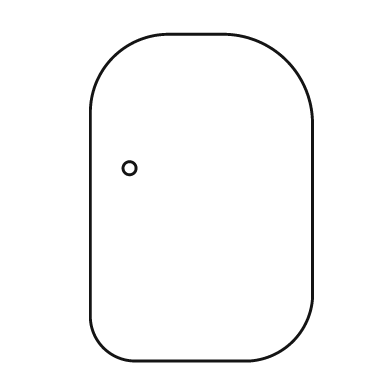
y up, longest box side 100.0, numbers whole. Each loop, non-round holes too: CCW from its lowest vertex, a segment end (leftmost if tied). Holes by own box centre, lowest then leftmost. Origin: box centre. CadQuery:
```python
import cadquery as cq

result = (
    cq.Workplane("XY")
    .moveTo(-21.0, -50.0)
    .lineTo(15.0, -50.0)
    .threePointArc((28.0, -44.0), (34.0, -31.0))
    .lineTo(34.0, 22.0)
    .threePointArc((26.0, 42.0), (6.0, 50.0))
    .lineTo(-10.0, 50.0)
    .threePointArc((-27.0, 43.0), (-34.0, 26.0))
    .lineTo(-34.0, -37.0)
    .threePointArc((-30.0, -46.0), (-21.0, -50.0))
    .close()
    .moveTo(-22.0, 9.0)
    .circle(2.0)
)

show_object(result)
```